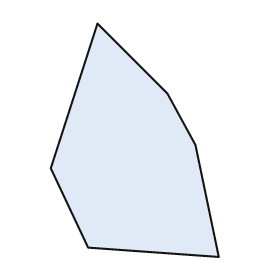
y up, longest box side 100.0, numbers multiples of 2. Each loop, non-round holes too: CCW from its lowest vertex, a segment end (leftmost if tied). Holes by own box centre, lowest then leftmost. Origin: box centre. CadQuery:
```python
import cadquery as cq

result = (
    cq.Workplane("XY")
    .moveTo(36.0, -50.0)
    .lineTo(26.0, -2.0)
    .lineTo(14.0, 20.0)
    .lineTo(-16.0, 50.0)
    .lineTo(-36.0, -12.0)
    .lineTo(-20.0, -46.0)
    .close()
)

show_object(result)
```